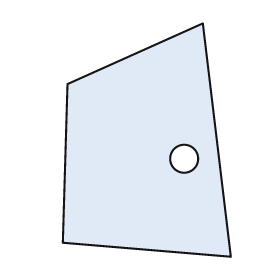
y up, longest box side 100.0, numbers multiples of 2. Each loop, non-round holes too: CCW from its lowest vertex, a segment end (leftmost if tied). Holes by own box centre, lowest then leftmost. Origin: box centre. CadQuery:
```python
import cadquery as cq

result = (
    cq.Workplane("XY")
    .moveTo(36.0, -50.0)
    .lineTo(24.0, 50.0)
    .lineTo(-34.0, 24.0)
    .lineTo(-36.0, -44.0)
    .close()
    .moveTo(16.0, -8.0)
    .circle(6.0)
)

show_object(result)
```